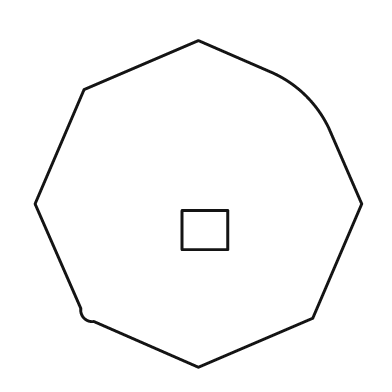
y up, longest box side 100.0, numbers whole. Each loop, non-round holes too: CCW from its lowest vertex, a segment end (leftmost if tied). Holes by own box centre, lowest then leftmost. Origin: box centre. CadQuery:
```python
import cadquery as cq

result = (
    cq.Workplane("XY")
    .moveTo(0.0, -50.0)
    .lineTo(35.0, -35.0)
    .lineTo(50.0, 0.0)
    .lineTo(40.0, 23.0)
    .threePointArc((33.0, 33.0), (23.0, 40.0))
    .lineTo(0.0, 50.0)
    .lineTo(-35.0, 35.0)
    .lineTo(-50.0, 0.0)
    .lineTo(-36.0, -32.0)
    .threePointArc((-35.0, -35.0), (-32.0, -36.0))
    .close()
    .moveTo(-5.0, -14.0)
    .lineTo(9.0, -14.0)
    .lineTo(9.0, -2.0)
    .lineTo(-5.0, -2.0)
    .close()
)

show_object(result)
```